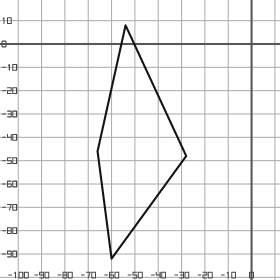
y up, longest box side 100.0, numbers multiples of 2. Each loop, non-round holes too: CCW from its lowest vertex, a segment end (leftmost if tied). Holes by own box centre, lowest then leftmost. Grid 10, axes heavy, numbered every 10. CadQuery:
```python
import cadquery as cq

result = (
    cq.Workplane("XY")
    .moveTo(-60.0, -92.0)
    .lineTo(-28.0, -48.0)
    .lineTo(-54.0, 8.0)
    .lineTo(-66.0, -46.0)
    .close()
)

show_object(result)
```